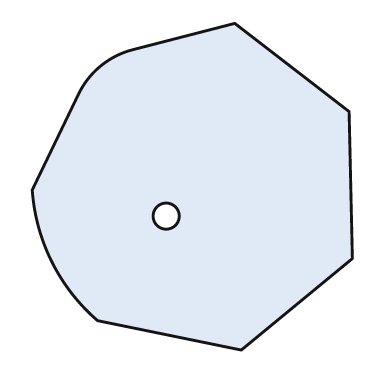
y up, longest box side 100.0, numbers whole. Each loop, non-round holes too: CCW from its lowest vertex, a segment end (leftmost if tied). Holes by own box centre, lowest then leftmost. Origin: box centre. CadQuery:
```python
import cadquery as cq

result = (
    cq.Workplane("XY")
    .moveTo(15.0, -50.0)
    .lineTo(49.0, -22.0)
    .lineTo(48.0, 23.0)
    .lineTo(13.0, 50.0)
    .lineTo(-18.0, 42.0)
    .threePointArc((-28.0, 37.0), (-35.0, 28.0))
    .lineTo(-49.0, -1.0)
    .threePointArc((-43.0, -23.0), (-29.0, -41.0))
    .close()
    .moveTo(-8.0, -9.0)
    .circle(4.0)
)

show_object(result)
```